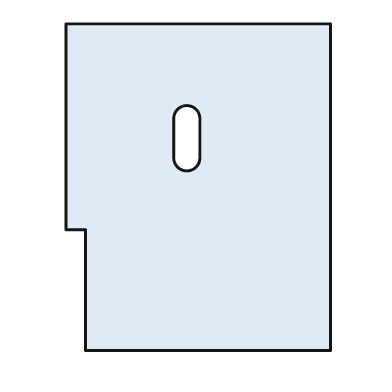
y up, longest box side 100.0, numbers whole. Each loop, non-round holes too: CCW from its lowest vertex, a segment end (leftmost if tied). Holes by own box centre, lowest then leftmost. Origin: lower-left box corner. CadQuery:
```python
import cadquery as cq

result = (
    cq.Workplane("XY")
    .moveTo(6.0, 0.0)
    .lineTo(81.0, 0.0)
    .lineTo(81.0, 100.0)
    .lineTo(0.0, 100.0)
    .lineTo(0.0, 37.0)
    .lineTo(6.0, 37.0)
    .close()
    .moveTo(33.0, 59.0)
    .threePointArc((37.0, 55.0), (41.0, 59.0))
    .lineTo(41.0, 71.0)
    .threePointArc((37.0, 75.0), (33.0, 71.0))
    .close()
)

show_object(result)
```